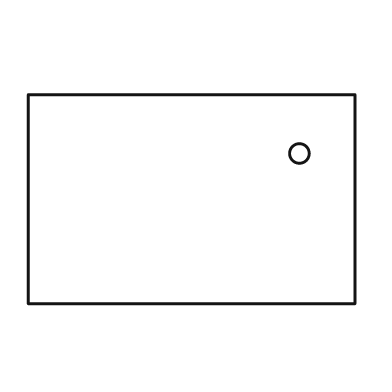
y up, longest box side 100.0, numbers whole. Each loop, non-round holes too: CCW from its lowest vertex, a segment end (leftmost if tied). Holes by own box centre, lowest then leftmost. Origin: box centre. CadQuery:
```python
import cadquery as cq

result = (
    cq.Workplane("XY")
    .moveTo(-50.0, -32.0)
    .lineTo(50.0, -32.0)
    .lineTo(50.0, 32.0)
    .lineTo(-50.0, 32.0)
    .close()
    .moveTo(33.0, 14.0)
    .circle(3.0)
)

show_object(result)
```